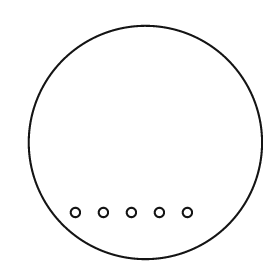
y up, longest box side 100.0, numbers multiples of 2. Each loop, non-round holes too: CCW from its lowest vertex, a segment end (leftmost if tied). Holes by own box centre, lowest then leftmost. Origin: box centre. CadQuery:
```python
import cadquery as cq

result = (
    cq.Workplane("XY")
    .moveTo(0.0, 0.0)
    .circle(50.0)
    .moveTo(-30.0, -30.0)
    .circle(2.0)
    .moveTo(-18.0, -30.0)
    .circle(2.0)
    .moveTo(-6.0, -30.0)
    .circle(2.0)
    .moveTo(6.0, -30.0)
    .circle(2.0)
    .moveTo(18.0, -30.0)
    .circle(2.0)
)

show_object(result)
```